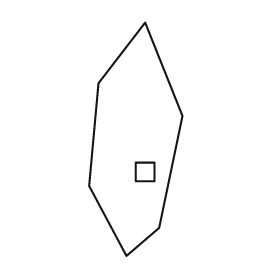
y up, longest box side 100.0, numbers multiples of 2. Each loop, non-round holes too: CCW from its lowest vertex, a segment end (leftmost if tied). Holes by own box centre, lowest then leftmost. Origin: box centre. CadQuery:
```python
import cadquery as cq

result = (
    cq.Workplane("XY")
    .moveTo(-4.0, -50.0)
    .lineTo(10.0, -38.0)
    .lineTo(20.0, 10.0)
    .lineTo(4.0, 50.0)
    .lineTo(-16.0, 24.0)
    .lineTo(-20.0, -20.0)
    .close()
    .moveTo(0.0, -18.0)
    .lineTo(8.0, -18.0)
    .lineTo(8.0, -10.0)
    .lineTo(0.0, -10.0)
    .close()
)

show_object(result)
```